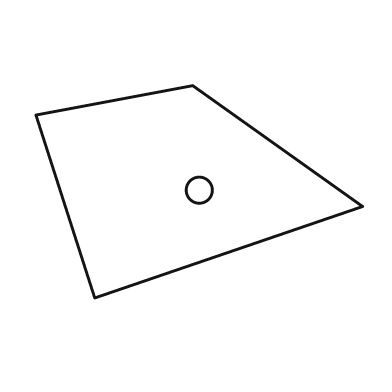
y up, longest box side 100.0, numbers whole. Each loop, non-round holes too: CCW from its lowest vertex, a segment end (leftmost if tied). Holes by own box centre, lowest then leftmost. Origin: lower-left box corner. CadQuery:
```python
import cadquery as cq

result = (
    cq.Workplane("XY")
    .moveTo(18.0, 0.0)
    .lineTo(100.0, 28.0)
    .lineTo(48.0, 65.0)
    .lineTo(0.0, 56.0)
    .close()
    .moveTo(50.0, 33.0)
    .circle(4.0)
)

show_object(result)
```